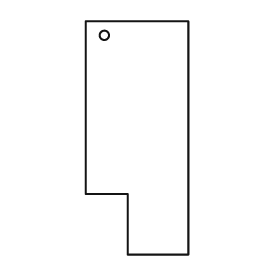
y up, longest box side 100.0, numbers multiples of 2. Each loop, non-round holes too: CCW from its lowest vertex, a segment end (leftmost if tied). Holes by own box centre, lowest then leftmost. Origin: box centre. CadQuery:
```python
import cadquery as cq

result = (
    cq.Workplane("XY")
    .moveTo(-4.0, -50.0)
    .lineTo(22.0, -50.0)
    .lineTo(22.0, 50.0)
    .lineTo(-22.0, 50.0)
    .lineTo(-22.0, -24.0)
    .lineTo(-4.0, -24.0)
    .close()
    .moveTo(-14.0, 44.0)
    .circle(2.0)
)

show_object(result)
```